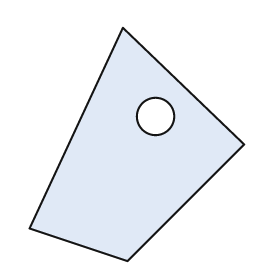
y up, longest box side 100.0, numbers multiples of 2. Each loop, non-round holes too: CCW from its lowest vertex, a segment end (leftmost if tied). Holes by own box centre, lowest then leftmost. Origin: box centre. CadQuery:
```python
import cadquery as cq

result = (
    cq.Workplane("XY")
    .moveTo(-4.0, -50.0)
    .lineTo(46.0, 0.0)
    .lineTo(-6.0, 50.0)
    .lineTo(-46.0, -36.0)
    .close()
    .moveTo(8.0, 12.0)
    .circle(8.0)
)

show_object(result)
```